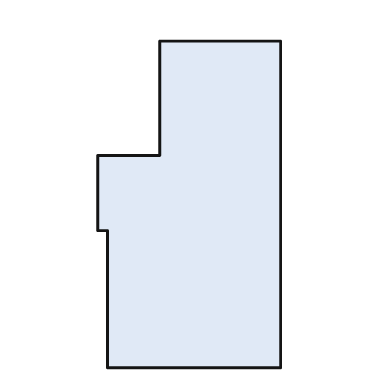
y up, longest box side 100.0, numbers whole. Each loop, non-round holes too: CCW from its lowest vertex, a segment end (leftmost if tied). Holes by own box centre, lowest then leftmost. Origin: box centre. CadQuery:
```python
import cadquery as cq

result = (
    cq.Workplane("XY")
    .moveTo(-25.0, -50.0)
    .lineTo(28.0, -50.0)
    .lineTo(28.0, 50.0)
    .lineTo(-9.0, 50.0)
    .lineTo(-9.0, 15.0)
    .lineTo(-28.0, 15.0)
    .lineTo(-28.0, -8.0)
    .lineTo(-25.0, -8.0)
    .close()
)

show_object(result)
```